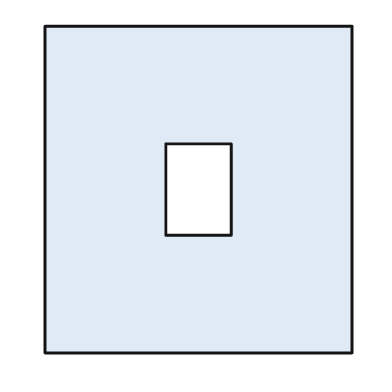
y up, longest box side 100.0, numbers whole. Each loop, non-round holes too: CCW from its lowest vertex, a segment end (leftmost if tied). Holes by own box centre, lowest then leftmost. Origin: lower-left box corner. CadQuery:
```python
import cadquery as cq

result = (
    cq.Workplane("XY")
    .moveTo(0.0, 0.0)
    .lineTo(94.0, 0.0)
    .lineTo(94.0, 100.0)
    .lineTo(0.0, 100.0)
    .close()
    .moveTo(37.0, 36.0)
    .lineTo(57.0, 36.0)
    .lineTo(57.0, 64.0)
    .lineTo(37.0, 64.0)
    .close()
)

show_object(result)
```